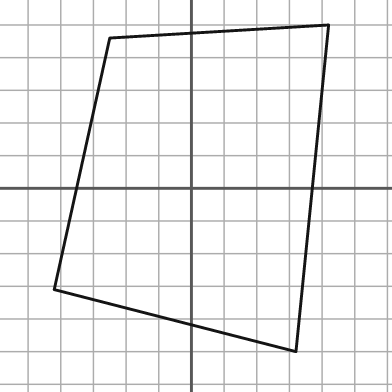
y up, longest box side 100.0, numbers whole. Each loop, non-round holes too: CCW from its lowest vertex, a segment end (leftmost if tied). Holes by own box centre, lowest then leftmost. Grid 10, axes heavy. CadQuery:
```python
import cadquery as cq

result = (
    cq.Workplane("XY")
    .moveTo(32.0, -50.0)
    .lineTo(42.0, 50.0)
    .lineTo(-25.0, 46.0)
    .lineTo(-42.0, -31.0)
    .close()
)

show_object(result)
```